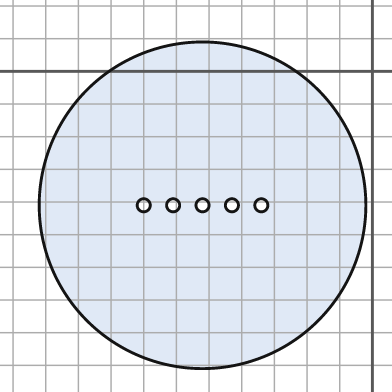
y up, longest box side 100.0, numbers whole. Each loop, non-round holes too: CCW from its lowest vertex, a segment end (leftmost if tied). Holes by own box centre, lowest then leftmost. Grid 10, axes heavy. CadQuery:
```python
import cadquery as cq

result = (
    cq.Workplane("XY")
    .moveTo(-52.0, -41.0)
    .circle(50.0)
    .moveTo(-70.0, -41.0)
    .circle(2.0)
    .moveTo(-61.0, -41.0)
    .circle(2.0)
    .moveTo(-52.0, -41.0)
    .circle(2.0)
    .moveTo(-43.0, -41.0)
    .circle(2.0)
    .moveTo(-34.0, -41.0)
    .circle(2.0)
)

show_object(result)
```